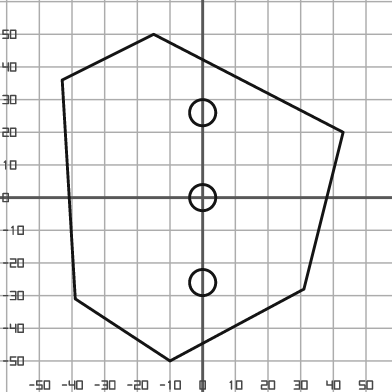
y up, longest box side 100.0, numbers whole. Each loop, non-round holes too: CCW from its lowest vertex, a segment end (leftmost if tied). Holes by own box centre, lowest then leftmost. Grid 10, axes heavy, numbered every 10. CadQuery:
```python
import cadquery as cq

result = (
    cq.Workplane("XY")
    .moveTo(-10.0, -50.0)
    .lineTo(31.0, -28.0)
    .lineTo(43.0, 20.0)
    .lineTo(-15.0, 50.0)
    .lineTo(-43.0, 36.0)
    .lineTo(-39.0, -31.0)
    .close()
    .moveTo(0.0, -26.0)
    .circle(4.0)
    .moveTo(0.0, 0.0)
    .circle(4.0)
    .moveTo(0.0, 26.0)
    .circle(4.0)
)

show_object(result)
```